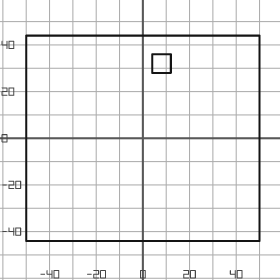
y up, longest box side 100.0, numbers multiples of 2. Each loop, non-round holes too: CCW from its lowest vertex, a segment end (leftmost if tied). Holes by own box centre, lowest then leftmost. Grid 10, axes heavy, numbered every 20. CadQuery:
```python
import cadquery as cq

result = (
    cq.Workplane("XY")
    .moveTo(-50.0, -44.0)
    .lineTo(50.0, -44.0)
    .lineTo(50.0, 44.0)
    .lineTo(-50.0, 44.0)
    .close()
    .moveTo(4.0, 28.0)
    .lineTo(12.0, 28.0)
    .lineTo(12.0, 36.0)
    .lineTo(4.0, 36.0)
    .close()
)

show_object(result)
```